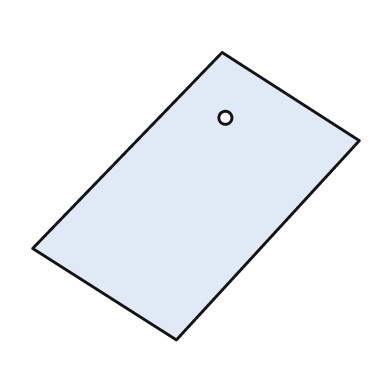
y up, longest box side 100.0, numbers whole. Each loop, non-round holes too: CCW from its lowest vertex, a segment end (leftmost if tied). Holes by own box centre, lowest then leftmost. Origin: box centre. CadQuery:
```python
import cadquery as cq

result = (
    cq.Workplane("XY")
    .moveTo(-6.0, -44.0)
    .lineTo(50.0, 17.0)
    .lineTo(8.0, 44.0)
    .lineTo(-50.0, -16.0)
    .close()
    .moveTo(9.0, 24.0)
    .circle(2.0)
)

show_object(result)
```